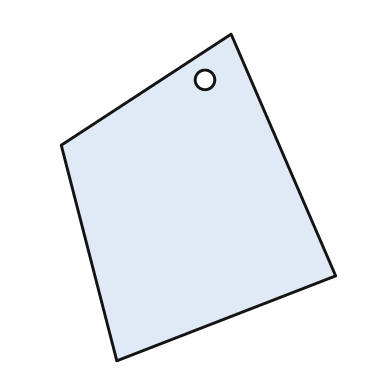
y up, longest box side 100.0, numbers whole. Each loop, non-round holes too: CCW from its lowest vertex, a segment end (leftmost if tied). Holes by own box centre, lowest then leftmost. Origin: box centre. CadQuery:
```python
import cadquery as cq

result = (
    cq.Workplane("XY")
    .moveTo(-25.0, -50.0)
    .lineTo(42.0, -24.0)
    .lineTo(10.0, 50.0)
    .lineTo(-42.0, 16.0)
    .close()
    .moveTo(2.0, 36.0)
    .circle(3.0)
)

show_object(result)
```